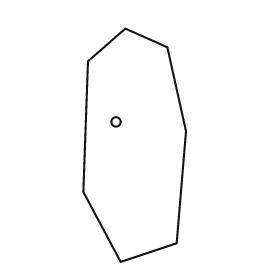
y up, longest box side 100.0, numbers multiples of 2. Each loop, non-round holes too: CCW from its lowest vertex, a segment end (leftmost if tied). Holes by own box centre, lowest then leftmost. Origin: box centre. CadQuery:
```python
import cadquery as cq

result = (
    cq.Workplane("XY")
    .moveTo(-6.0, -50.0)
    .lineTo(18.0, -42.0)
    .lineTo(22.0, 6.0)
    .lineTo(14.0, 42.0)
    .lineTo(-4.0, 50.0)
    .lineTo(-20.0, 36.0)
    .lineTo(-22.0, -20.0)
    .close()
    .moveTo(-8.0, 10.0)
    .circle(2.0)
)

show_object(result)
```